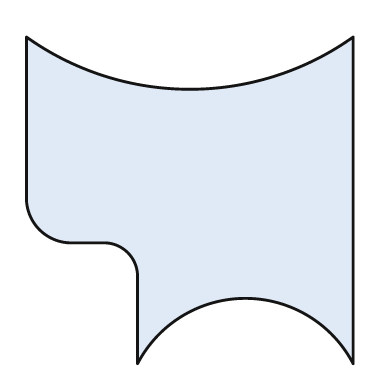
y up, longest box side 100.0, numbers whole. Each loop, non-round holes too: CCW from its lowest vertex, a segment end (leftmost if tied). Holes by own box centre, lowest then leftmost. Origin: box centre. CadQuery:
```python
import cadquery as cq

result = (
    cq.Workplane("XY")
    .moveTo(-16.0, -50.0)
    .threePointArc((17.0, -30.0), (50.0, -50.0))
    .lineTo(50.0, 50.0)
    .threePointArc((0.0, 34.0), (-50.0, 50.0))
    .lineTo(-50.0, 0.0)
    .threePointArc((-46.0, -9.0), (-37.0, -13.0))
    .lineTo(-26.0, -13.0)
    .threePointArc((-19.0, -16.0), (-16.0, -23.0))
    .close()
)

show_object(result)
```